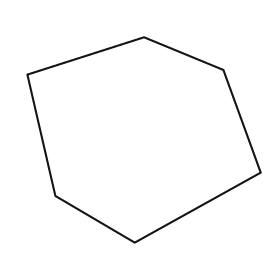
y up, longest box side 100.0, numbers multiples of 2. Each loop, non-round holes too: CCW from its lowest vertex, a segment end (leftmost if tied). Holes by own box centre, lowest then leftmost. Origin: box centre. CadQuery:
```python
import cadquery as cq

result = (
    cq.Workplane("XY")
    .moveTo(-4.0, -44.0)
    .lineTo(50.0, -14.0)
    .lineTo(34.0, 30.0)
    .lineTo(0.0, 44.0)
    .lineTo(-50.0, 28.0)
    .lineTo(-38.0, -24.0)
    .close()
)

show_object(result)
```